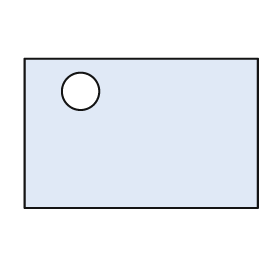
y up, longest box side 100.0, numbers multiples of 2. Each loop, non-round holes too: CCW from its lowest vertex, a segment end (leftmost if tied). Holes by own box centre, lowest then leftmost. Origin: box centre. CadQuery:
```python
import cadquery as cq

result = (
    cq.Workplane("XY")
    .moveTo(-50.0, -32.0)
    .lineTo(50.0, -32.0)
    .lineTo(50.0, 32.0)
    .lineTo(-50.0, 32.0)
    .close()
    .moveTo(-26.0, 18.0)
    .circle(8.0)
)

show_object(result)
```